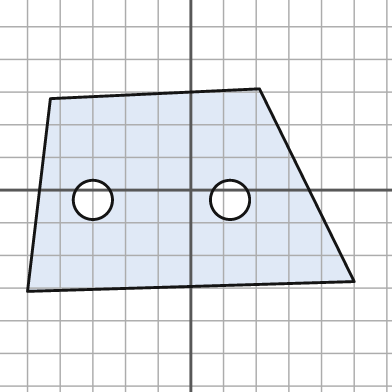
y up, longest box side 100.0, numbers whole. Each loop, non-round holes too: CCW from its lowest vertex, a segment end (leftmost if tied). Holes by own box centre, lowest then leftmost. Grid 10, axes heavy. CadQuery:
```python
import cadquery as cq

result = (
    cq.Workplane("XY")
    .moveTo(-50.0, -31.0)
    .lineTo(50.0, -28.0)
    .lineTo(21.0, 31.0)
    .lineTo(-43.0, 28.0)
    .close()
    .moveTo(-30.0, -3.0)
    .circle(6.0)
    .moveTo(12.0, -3.0)
    .circle(6.0)
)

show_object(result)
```